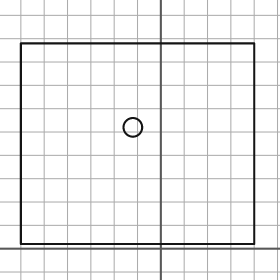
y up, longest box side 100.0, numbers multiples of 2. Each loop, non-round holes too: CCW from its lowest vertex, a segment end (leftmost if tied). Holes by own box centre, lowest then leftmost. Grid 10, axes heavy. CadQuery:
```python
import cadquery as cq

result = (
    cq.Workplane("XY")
    .moveTo(-60.0, 2.0)
    .lineTo(40.0, 2.0)
    .lineTo(40.0, 88.0)
    .lineTo(-60.0, 88.0)
    .close()
    .moveTo(-12.0, 52.0)
    .circle(4.0)
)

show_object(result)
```